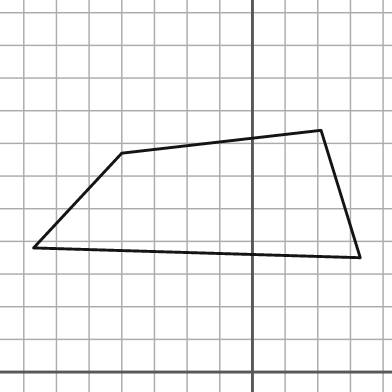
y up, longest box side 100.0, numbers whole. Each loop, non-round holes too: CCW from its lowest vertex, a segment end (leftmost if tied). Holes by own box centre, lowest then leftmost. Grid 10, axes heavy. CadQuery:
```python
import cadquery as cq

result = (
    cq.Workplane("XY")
    .moveTo(33.0, 35.0)
    .lineTo(21.0, 74.0)
    .lineTo(-40.0, 67.0)
    .lineTo(-67.0, 38.0)
    .close()
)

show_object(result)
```